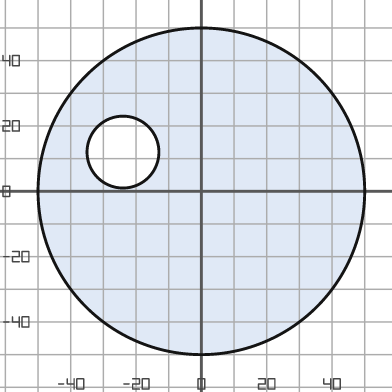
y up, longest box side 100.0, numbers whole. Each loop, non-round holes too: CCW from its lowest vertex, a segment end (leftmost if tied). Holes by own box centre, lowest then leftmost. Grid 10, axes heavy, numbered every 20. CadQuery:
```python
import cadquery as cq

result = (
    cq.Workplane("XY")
    .moveTo(0.0, 0.0)
    .circle(50.0)
    .moveTo(-24.0, 12.0)
    .circle(11.0)
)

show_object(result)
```